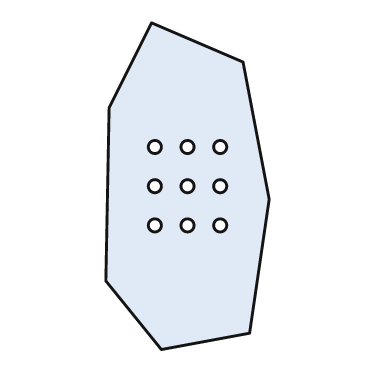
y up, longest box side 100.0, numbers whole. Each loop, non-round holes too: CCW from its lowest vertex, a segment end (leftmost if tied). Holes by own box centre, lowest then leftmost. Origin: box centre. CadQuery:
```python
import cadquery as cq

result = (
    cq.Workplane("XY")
    .moveTo(-8.0, -50.0)
    .lineTo(19.0, -45.0)
    .lineTo(25.0, -4.0)
    .lineTo(17.0, 38.0)
    .lineTo(-11.0, 50.0)
    .lineTo(-24.0, 24.0)
    .lineTo(-25.0, -29.0)
    .close()
    .moveTo(-10.0, -12.0)
    .circle(2.0)
    .moveTo(0.0, -12.0)
    .circle(2.0)
    .moveTo(10.0, -12.0)
    .circle(2.0)
    .moveTo(-10.0, 0.0)
    .circle(2.0)
    .moveTo(0.0, 0.0)
    .circle(2.0)
    .moveTo(10.0, 0.0)
    .circle(2.0)
    .moveTo(-10.0, 12.0)
    .circle(2.0)
    .moveTo(0.0, 12.0)
    .circle(2.0)
    .moveTo(10.0, 12.0)
    .circle(2.0)
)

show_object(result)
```